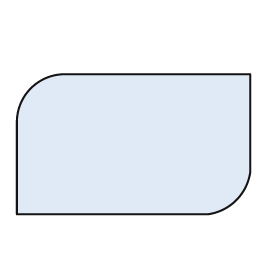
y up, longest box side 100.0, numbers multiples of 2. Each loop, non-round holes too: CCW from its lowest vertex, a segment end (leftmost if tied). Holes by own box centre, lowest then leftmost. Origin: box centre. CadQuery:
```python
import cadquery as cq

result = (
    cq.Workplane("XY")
    .moveTo(-50.0, -30.0)
    .lineTo(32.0, -30.0)
    .threePointArc((44.0, -24.0), (50.0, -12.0))
    .lineTo(50.0, 30.0)
    .lineTo(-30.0, 30.0)
    .threePointArc((-44.0, 24.0), (-50.0, 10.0))
    .close()
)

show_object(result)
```